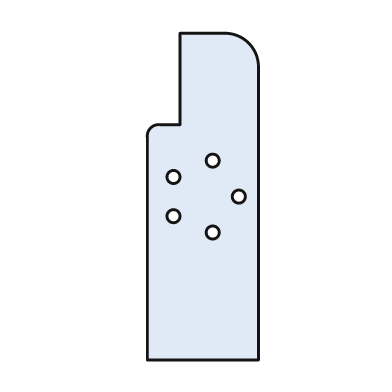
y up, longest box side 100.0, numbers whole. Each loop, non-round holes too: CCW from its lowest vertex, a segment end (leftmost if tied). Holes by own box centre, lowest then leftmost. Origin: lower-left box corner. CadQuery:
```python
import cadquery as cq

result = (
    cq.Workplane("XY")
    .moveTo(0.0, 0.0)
    .lineTo(34.0, 0.0)
    .lineTo(34.0, 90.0)
    .threePointArc((31.0, 97.0), (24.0, 100.0))
    .lineTo(10.0, 100.0)
    .lineTo(10.0, 72.0)
    .lineTo(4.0, 72.0)
    .threePointArc((1.0, 71.0), (0.0, 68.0))
    .close()
    .moveTo(20.0, 39.0)
    .circle(2.0)
    .moveTo(8.0, 44.0)
    .circle(2.0)
    .moveTo(28.0, 50.0)
    .circle(2.0)
    .moveTo(8.0, 56.0)
    .circle(2.0)
    .moveTo(20.0, 61.0)
    .circle(2.0)
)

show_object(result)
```